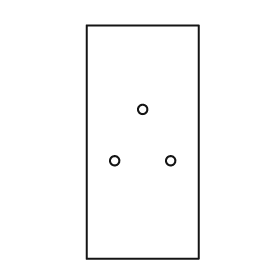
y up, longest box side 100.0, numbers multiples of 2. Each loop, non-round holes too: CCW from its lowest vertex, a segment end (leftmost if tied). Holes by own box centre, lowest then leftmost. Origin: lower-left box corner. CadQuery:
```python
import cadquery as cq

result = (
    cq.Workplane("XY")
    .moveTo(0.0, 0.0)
    .lineTo(48.0, 0.0)
    .lineTo(48.0, 100.0)
    .lineTo(0.0, 100.0)
    .close()
    .moveTo(12.0, 42.0)
    .circle(2.0)
    .moveTo(36.0, 42.0)
    .circle(2.0)
    .moveTo(24.0, 64.0)
    .circle(2.0)
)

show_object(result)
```